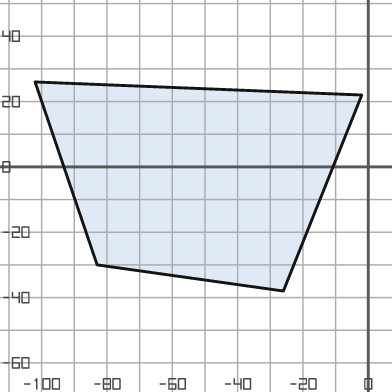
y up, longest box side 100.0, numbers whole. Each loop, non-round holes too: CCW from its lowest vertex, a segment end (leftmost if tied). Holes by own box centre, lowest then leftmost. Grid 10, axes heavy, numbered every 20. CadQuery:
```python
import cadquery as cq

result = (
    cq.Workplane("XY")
    .moveTo(-26.0, -38.0)
    .lineTo(-2.0, 22.0)
    .lineTo(-102.0, 26.0)
    .lineTo(-83.0, -30.0)
    .close()
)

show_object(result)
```